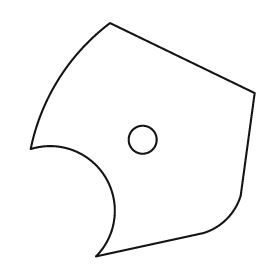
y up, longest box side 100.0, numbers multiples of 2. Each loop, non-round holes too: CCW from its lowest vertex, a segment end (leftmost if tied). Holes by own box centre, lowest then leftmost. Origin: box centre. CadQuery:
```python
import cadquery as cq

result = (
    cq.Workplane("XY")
    .moveTo(-20.0, -50.0)
    .lineTo(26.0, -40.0)
    .threePointArc((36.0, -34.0), (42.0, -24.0))
    .lineTo(48.0, 20.0)
    .lineTo(-14.0, 50.0)
    .threePointArc((-36.0, 26.0), (-48.0, -4.0))
    .threePointArc((-16.0, -16.0), (-20.0, -50.0))
    .close()
    .moveTo(0.0, 0.0)
    .circle(6.0)
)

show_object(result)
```